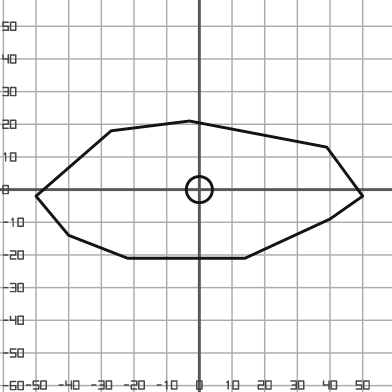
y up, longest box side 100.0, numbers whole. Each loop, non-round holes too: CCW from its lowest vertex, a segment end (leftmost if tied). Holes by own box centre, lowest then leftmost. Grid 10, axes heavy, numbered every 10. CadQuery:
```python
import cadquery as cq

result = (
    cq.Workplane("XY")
    .moveTo(-22.0, -21.0)
    .lineTo(14.0, -21.0)
    .lineTo(40.0, -9.0)
    .lineTo(50.0, -2.0)
    .lineTo(39.0, 13.0)
    .lineTo(-3.0, 21.0)
    .lineTo(-27.0, 18.0)
    .lineTo(-50.0, -2.0)
    .lineTo(-40.0, -14.0)
    .close()
    .moveTo(0.0, 0.0)
    .circle(4.0)
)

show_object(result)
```